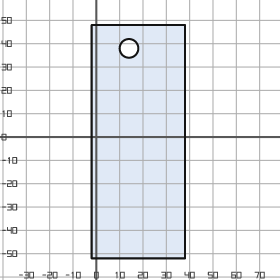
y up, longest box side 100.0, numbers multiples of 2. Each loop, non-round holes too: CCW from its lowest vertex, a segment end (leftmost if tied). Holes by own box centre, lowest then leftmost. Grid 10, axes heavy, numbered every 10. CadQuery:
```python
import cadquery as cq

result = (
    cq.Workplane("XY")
    .moveTo(-2.0, -52.0)
    .lineTo(38.0, -52.0)
    .lineTo(38.0, 48.0)
    .lineTo(-2.0, 48.0)
    .close()
    .moveTo(14.0, 38.0)
    .circle(4.0)
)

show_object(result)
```